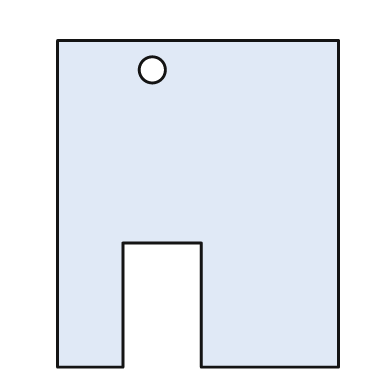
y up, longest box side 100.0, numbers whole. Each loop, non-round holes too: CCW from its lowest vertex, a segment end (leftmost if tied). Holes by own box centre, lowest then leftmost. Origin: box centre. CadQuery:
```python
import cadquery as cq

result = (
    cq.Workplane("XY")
    .moveTo(-43.0, -50.0)
    .lineTo(-23.0, -50.0)
    .lineTo(-23.0, -12.0)
    .lineTo(1.0, -12.0)
    .lineTo(1.0, -50.0)
    .lineTo(43.0, -50.0)
    .lineTo(43.0, 50.0)
    .lineTo(-43.0, 50.0)
    .close()
    .moveTo(-14.0, 41.0)
    .circle(4.0)
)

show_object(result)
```